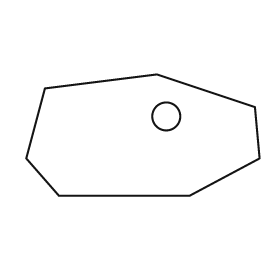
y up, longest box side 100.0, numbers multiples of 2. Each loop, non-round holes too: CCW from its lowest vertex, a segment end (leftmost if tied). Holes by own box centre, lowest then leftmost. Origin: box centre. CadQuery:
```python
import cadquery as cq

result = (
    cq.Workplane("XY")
    .moveTo(-36.0, -26.0)
    .lineTo(20.0, -26.0)
    .lineTo(50.0, -10.0)
    .lineTo(48.0, 12.0)
    .lineTo(6.0, 26.0)
    .lineTo(-42.0, 20.0)
    .lineTo(-50.0, -10.0)
    .close()
    .moveTo(10.0, 8.0)
    .circle(6.0)
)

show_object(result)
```